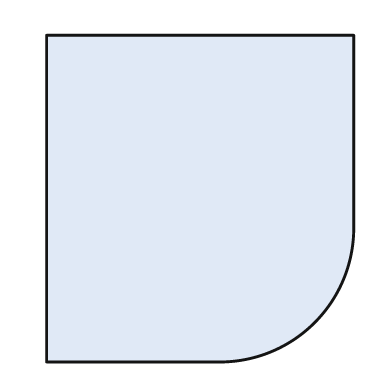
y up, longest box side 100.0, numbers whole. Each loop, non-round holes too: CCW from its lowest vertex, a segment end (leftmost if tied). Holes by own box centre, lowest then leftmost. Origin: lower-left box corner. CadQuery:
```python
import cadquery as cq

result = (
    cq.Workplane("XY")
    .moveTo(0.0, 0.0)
    .lineTo(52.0, 0.0)
    .threePointArc((82.0, 12.0), (94.0, 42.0))
    .lineTo(94.0, 100.0)
    .lineTo(0.0, 100.0)
    .close()
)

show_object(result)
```